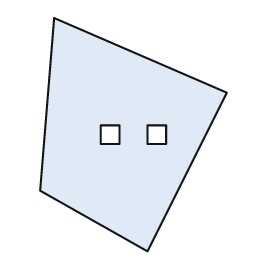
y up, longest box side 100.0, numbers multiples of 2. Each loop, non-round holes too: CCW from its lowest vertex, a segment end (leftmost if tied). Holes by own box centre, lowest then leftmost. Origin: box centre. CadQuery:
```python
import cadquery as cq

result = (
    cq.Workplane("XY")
    .moveTo(6.0, -50.0)
    .lineTo(40.0, 18.0)
    .lineTo(-34.0, 50.0)
    .lineTo(-40.0, -24.0)
    .close()
    .moveTo(-14.0, -4.0)
    .lineTo(-6.0, -4.0)
    .lineTo(-6.0, 4.0)
    .lineTo(-14.0, 4.0)
    .close()
    .moveTo(6.0, -4.0)
    .lineTo(14.0, -4.0)
    .lineTo(14.0, 4.0)
    .lineTo(6.0, 4.0)
    .close()
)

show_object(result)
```